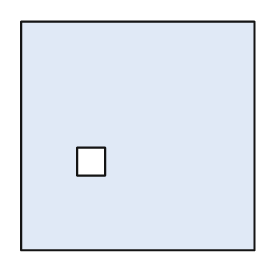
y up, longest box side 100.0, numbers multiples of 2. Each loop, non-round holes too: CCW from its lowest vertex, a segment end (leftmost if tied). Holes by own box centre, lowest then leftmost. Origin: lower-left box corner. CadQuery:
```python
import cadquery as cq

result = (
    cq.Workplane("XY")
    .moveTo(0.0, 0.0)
    .lineTo(100.0, 0.0)
    .lineTo(100.0, 98.0)
    .lineTo(0.0, 98.0)
    .close()
    .moveTo(24.0, 32.0)
    .lineTo(36.0, 32.0)
    .lineTo(36.0, 44.0)
    .lineTo(24.0, 44.0)
    .close()
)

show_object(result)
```